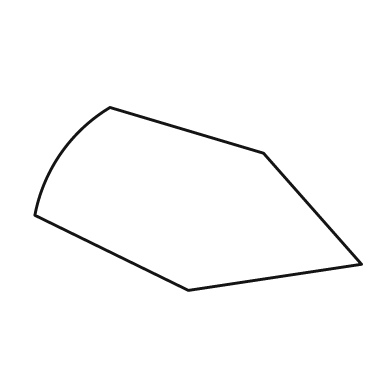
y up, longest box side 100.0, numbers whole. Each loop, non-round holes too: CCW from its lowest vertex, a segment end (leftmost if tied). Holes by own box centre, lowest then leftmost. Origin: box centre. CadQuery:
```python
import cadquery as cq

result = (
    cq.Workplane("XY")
    .moveTo(-3.0, -28.0)
    .lineTo(50.0, -20.0)
    .lineTo(20.0, 14.0)
    .lineTo(-27.0, 28.0)
    .threePointArc((-42.0, 14.0), (-50.0, -5.0))
    .close()
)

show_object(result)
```